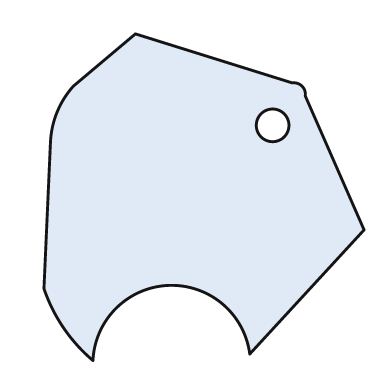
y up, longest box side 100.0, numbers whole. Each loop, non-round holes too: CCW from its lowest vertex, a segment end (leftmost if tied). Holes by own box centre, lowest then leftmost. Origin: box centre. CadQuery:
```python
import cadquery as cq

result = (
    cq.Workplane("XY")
    .moveTo(-34.0, -50.0)
    .threePointArc((-11.0, -27.0), (14.0, -48.0))
    .lineTo(49.0, -10.0)
    .lineTo(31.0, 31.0)
    .threePointArc((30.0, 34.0), (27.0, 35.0))
    .lineTo(-21.0, 50.0)
    .lineTo(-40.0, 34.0)
    .threePointArc((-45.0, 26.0), (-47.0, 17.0))
    .lineTo(-49.0, -28.0)
    .threePointArc((-43.0, -40.0), (-34.0, -50.0))
    .close()
    .moveTo(21.0, 22.0)
    .circle(5.0)
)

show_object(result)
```